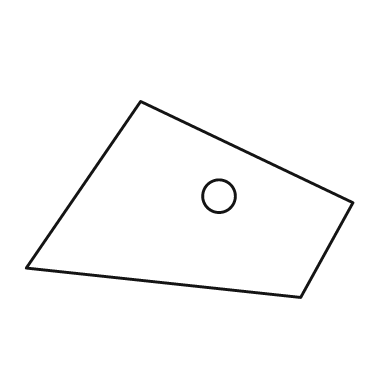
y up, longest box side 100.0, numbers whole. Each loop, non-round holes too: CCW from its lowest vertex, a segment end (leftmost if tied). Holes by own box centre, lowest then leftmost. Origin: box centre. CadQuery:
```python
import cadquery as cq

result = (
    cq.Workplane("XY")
    .moveTo(34.0, -30.0)
    .lineTo(50.0, -1.0)
    .lineTo(-15.0, 30.0)
    .lineTo(-50.0, -21.0)
    .close()
    .moveTo(9.0, 1.0)
    .circle(5.0)
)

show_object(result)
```